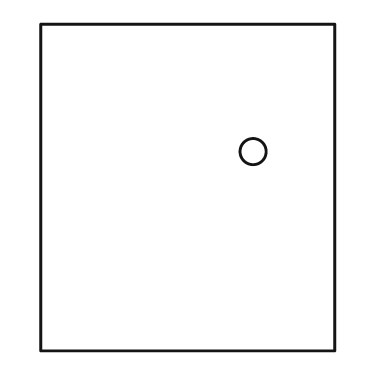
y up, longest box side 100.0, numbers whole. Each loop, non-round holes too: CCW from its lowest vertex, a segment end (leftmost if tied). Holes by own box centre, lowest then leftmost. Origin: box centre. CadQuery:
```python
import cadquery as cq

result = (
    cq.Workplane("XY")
    .moveTo(-45.0, -50.0)
    .lineTo(45.0, -50.0)
    .lineTo(45.0, 50.0)
    .lineTo(-45.0, 50.0)
    .close()
    .moveTo(20.0, 11.0)
    .circle(4.0)
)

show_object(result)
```